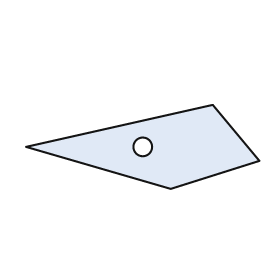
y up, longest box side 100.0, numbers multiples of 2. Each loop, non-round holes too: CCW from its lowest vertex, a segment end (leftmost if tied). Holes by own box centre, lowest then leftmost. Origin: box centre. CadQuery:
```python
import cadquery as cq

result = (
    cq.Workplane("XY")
    .moveTo(12.0, -18.0)
    .lineTo(50.0, -6.0)
    .lineTo(30.0, 18.0)
    .lineTo(-50.0, 0.0)
    .close()
    .moveTo(0.0, 0.0)
    .circle(4.0)
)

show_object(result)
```